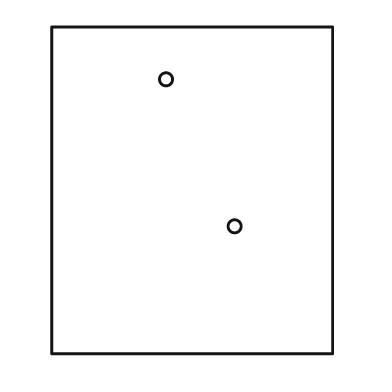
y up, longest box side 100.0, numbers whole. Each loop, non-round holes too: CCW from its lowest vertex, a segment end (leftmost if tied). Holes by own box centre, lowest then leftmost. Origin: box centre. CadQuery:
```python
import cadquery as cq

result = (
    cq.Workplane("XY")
    .moveTo(-43.0, -50.0)
    .lineTo(43.0, -50.0)
    .lineTo(43.0, 50.0)
    .lineTo(-43.0, 50.0)
    .close()
    .moveTo(13.0, -11.0)
    .circle(2.0)
    .moveTo(-8.0, 34.0)
    .circle(2.0)
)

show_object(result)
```